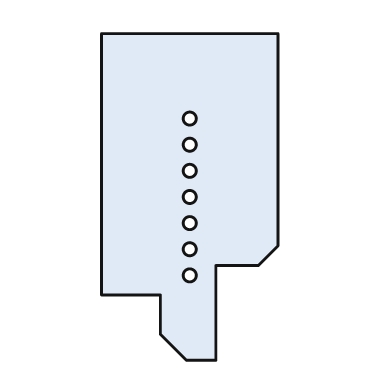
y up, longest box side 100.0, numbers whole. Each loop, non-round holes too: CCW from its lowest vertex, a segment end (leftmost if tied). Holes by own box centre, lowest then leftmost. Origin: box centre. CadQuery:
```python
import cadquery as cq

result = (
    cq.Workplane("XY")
    .moveTo(-1.0, -50.0)
    .lineTo(8.0, -50.0)
    .lineTo(8.0, -21.0)
    .lineTo(21.0, -21.0)
    .lineTo(27.0, -15.0)
    .lineTo(27.0, 50.0)
    .lineTo(-27.0, 50.0)
    .lineTo(-27.0, -30.0)
    .lineTo(-9.0, -30.0)
    .lineTo(-9.0, -42.0)
    .close()
    .moveTo(0.0, -24.0)
    .circle(2.0)
    .moveTo(0.0, -16.0)
    .circle(2.0)
    .moveTo(0.0, -8.0)
    .circle(2.0)
    .moveTo(0.0, 0.0)
    .circle(2.0)
    .moveTo(0.0, 8.0)
    .circle(2.0)
    .moveTo(0.0, 16.0)
    .circle(2.0)
    .moveTo(0.0, 24.0)
    .circle(2.0)
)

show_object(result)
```